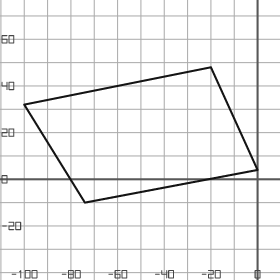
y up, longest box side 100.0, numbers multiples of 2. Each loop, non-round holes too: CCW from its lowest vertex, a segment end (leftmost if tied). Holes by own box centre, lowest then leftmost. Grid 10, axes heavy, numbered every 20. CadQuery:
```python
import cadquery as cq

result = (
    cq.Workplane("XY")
    .moveTo(-74.0, -10.0)
    .lineTo(0.0, 4.0)
    .lineTo(-20.0, 48.0)
    .lineTo(-100.0, 32.0)
    .close()
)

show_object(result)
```